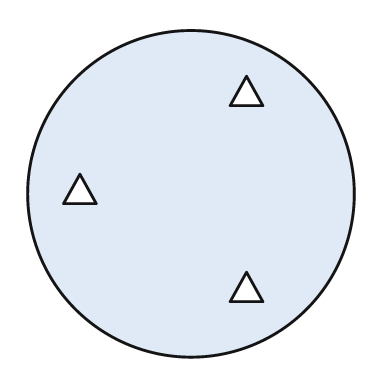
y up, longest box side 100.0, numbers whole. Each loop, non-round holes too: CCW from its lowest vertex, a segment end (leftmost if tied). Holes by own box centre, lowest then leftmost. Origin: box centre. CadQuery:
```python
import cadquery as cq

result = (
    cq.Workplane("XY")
    .moveTo(0.0, 0.0)
    .circle(50.0)
    .moveTo(12.0, -33.0)
    .lineTo(22.0, -33.0)
    .lineTo(17.0, -24.0)
    .close()
    .moveTo(-39.0, -3.0)
    .lineTo(-29.0, -3.0)
    .lineTo(-34.0, 6.0)
    .close()
    .moveTo(12.0, 27.0)
    .lineTo(22.0, 27.0)
    .lineTo(17.0, 36.0)
    .close()
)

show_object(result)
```